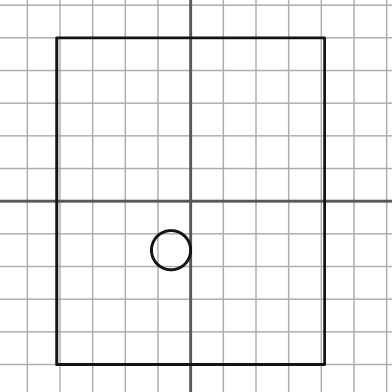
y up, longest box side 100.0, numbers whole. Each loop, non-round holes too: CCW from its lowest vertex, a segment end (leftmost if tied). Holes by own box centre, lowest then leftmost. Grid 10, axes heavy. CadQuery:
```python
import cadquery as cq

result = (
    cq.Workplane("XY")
    .moveTo(-41.0, -50.0)
    .lineTo(41.0, -50.0)
    .lineTo(41.0, 50.0)
    .lineTo(-41.0, 50.0)
    .close()
    .moveTo(-6.0, -15.0)
    .circle(6.0)
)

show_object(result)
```